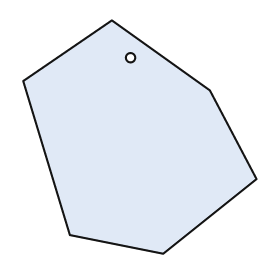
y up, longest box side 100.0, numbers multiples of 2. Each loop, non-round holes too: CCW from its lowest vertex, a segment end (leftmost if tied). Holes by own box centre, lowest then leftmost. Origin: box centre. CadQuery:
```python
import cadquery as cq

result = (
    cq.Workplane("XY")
    .moveTo(10.0, -50.0)
    .lineTo(50.0, -18.0)
    .lineTo(30.0, 20.0)
    .lineTo(-12.0, 50.0)
    .lineTo(-50.0, 24.0)
    .lineTo(-30.0, -42.0)
    .close()
    .moveTo(-4.0, 34.0)
    .circle(2.0)
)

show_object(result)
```